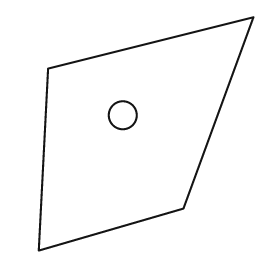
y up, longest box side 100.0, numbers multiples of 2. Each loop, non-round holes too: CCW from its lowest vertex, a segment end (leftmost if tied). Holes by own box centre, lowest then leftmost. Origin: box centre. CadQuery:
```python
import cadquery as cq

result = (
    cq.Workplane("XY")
    .moveTo(-46.0, -50.0)
    .lineTo(16.0, -32.0)
    .lineTo(46.0, 50.0)
    .lineTo(-42.0, 28.0)
    .close()
    .moveTo(-10.0, 8.0)
    .circle(6.0)
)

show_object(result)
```